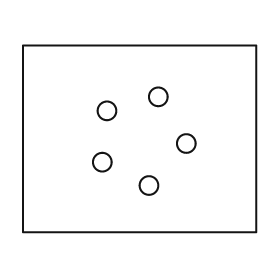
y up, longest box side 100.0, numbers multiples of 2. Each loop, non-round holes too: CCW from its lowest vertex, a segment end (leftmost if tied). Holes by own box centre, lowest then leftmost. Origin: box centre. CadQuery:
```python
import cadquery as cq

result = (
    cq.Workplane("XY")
    .moveTo(-50.0, -40.0)
    .lineTo(50.0, -40.0)
    .lineTo(50.0, 40.0)
    .lineTo(-50.0, 40.0)
    .close()
    .moveTo(4.0, -20.0)
    .circle(4.0)
    .moveTo(-16.0, -10.0)
    .circle(4.0)
    .moveTo(20.0, -2.0)
    .circle(4.0)
    .moveTo(-14.0, 12.0)
    .circle(4.0)
    .moveTo(8.0, 18.0)
    .circle(4.0)
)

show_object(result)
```